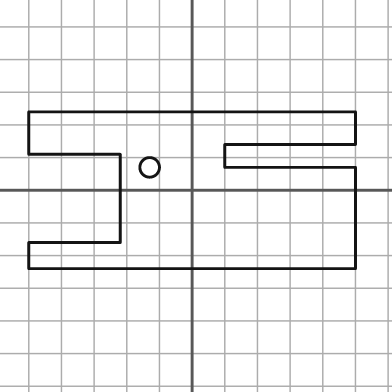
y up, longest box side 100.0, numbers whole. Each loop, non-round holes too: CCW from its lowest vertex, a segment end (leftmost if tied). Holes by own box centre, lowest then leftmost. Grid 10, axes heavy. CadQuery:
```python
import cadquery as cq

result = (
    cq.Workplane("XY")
    .moveTo(-50.0, -24.0)
    .lineTo(50.0, -24.0)
    .lineTo(50.0, 7.0)
    .lineTo(10.0, 7.0)
    .lineTo(10.0, 14.0)
    .lineTo(50.0, 14.0)
    .lineTo(50.0, 24.0)
    .lineTo(-50.0, 24.0)
    .lineTo(-50.0, 11.0)
    .lineTo(-22.0, 11.0)
    .lineTo(-22.0, -16.0)
    .lineTo(-50.0, -16.0)
    .close()
    .moveTo(-13.0, 7.0)
    .circle(3.0)
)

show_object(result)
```